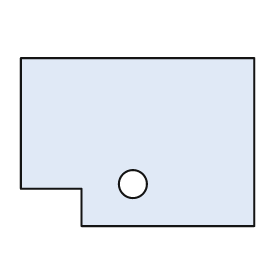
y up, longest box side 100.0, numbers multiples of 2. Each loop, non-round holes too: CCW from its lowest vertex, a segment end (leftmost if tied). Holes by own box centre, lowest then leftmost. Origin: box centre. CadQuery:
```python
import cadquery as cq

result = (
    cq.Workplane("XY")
    .moveTo(-24.0, -36.0)
    .lineTo(50.0, -36.0)
    .lineTo(50.0, 36.0)
    .lineTo(-50.0, 36.0)
    .lineTo(-50.0, -20.0)
    .lineTo(-24.0, -20.0)
    .close()
    .moveTo(-2.0, -18.0)
    .circle(6.0)
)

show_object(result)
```